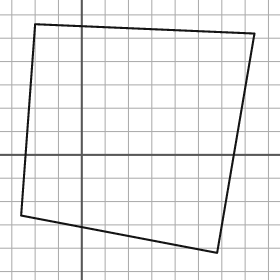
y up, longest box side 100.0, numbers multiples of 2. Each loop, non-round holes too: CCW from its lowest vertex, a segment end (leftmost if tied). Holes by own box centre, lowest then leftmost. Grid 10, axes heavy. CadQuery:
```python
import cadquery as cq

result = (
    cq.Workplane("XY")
    .moveTo(58.0, -42.0)
    .lineTo(74.0, 52.0)
    .lineTo(-20.0, 56.0)
    .lineTo(-26.0, -26.0)
    .close()
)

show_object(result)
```